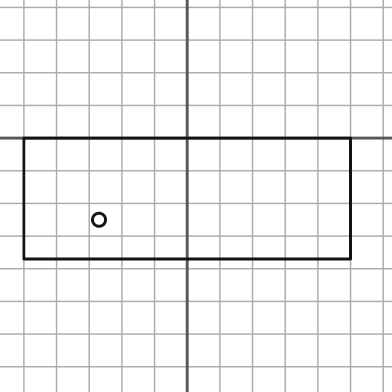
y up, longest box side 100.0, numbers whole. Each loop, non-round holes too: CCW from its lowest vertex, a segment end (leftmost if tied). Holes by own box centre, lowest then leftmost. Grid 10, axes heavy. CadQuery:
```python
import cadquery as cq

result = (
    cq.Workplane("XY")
    .moveTo(-50.0, -37.0)
    .lineTo(50.0, -37.0)
    .lineTo(50.0, 0.0)
    .lineTo(-50.0, 0.0)
    .close()
    .moveTo(-27.0, -25.0)
    .circle(2.0)
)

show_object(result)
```